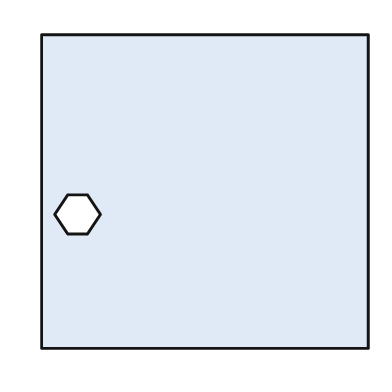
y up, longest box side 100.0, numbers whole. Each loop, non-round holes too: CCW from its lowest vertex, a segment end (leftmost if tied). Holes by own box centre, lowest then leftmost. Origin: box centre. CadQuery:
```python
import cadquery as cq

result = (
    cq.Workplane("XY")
    .moveTo(-50.0, -48.0)
    .lineTo(50.0, -48.0)
    .lineTo(50.0, 48.0)
    .lineTo(-50.0, 48.0)
    .close()
    .moveTo(-42.0, -13.0)
    .lineTo(-36.0, -13.0)
    .lineTo(-32.0, -7.0)
    .lineTo(-36.0, -1.0)
    .lineTo(-42.0, -1.0)
    .lineTo(-46.0, -7.0)
    .close()
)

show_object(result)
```